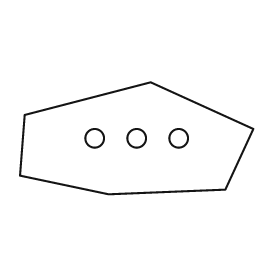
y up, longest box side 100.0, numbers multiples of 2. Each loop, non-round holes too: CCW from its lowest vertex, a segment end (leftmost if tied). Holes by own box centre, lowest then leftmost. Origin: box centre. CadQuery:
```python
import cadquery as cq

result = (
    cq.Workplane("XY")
    .moveTo(-12.0, -24.0)
    .lineTo(38.0, -22.0)
    .lineTo(50.0, 4.0)
    .lineTo(6.0, 24.0)
    .lineTo(-48.0, 10.0)
    .lineTo(-50.0, -16.0)
    .close()
    .moveTo(-18.0, 0.0)
    .circle(4.0)
    .moveTo(0.0, 0.0)
    .circle(4.0)
    .moveTo(18.0, 0.0)
    .circle(4.0)
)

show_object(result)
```